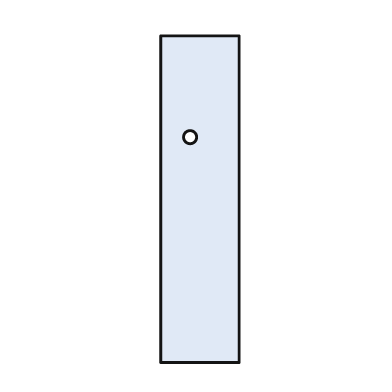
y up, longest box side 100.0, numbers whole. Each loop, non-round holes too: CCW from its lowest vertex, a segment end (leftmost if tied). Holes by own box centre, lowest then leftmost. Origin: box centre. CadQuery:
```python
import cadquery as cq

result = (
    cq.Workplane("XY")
    .moveTo(-12.0, -50.0)
    .lineTo(12.0, -50.0)
    .lineTo(12.0, 50.0)
    .lineTo(-12.0, 50.0)
    .close()
    .moveTo(-3.0, 19.0)
    .circle(2.0)
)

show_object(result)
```